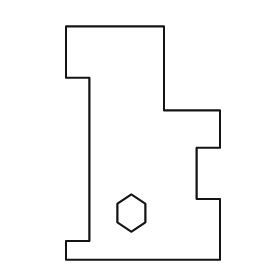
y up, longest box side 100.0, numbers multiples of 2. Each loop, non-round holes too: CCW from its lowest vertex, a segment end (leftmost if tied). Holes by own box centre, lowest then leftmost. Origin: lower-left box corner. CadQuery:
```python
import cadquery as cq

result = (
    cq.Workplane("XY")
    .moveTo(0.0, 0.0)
    .lineTo(66.0, 0.0)
    .lineTo(66.0, 26.0)
    .lineTo(56.0, 26.0)
    .lineTo(56.0, 48.0)
    .lineTo(66.0, 48.0)
    .lineTo(66.0, 64.0)
    .lineTo(42.0, 64.0)
    .lineTo(42.0, 100.0)
    .lineTo(0.0, 100.0)
    .lineTo(0.0, 78.0)
    .lineTo(10.0, 78.0)
    .lineTo(10.0, 8.0)
    .lineTo(0.0, 8.0)
    .close()
    .moveTo(28.0, 12.0)
    .lineTo(34.0, 16.0)
    .lineTo(34.0, 24.0)
    .lineTo(28.0, 28.0)
    .lineTo(22.0, 24.0)
    .lineTo(22.0, 16.0)
    .close()
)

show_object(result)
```